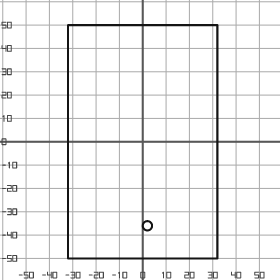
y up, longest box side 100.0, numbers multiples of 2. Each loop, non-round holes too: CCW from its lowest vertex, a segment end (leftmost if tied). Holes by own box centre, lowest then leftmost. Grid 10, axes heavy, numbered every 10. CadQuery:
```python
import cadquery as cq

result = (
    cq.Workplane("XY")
    .moveTo(-32.0, -50.0)
    .lineTo(32.0, -50.0)
    .lineTo(32.0, 50.0)
    .lineTo(-32.0, 50.0)
    .close()
    .moveTo(2.0, -36.0)
    .circle(2.0)
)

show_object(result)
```